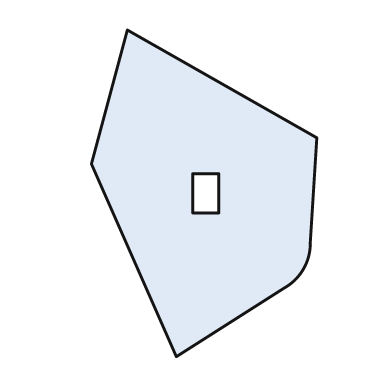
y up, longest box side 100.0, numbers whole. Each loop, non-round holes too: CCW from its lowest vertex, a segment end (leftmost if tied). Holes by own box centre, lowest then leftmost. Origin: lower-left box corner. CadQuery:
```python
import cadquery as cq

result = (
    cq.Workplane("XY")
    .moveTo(26.0, 0.0)
    .lineTo(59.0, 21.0)
    .threePointArc((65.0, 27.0), (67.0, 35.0))
    .lineTo(69.0, 67.0)
    .lineTo(11.0, 100.0)
    .lineTo(0.0, 59.0)
    .close()
    .moveTo(31.0, 44.0)
    .lineTo(39.0, 44.0)
    .lineTo(39.0, 56.0)
    .lineTo(31.0, 56.0)
    .close()
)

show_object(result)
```